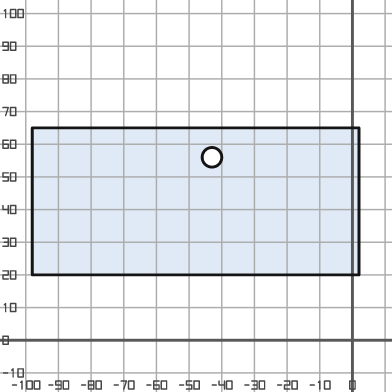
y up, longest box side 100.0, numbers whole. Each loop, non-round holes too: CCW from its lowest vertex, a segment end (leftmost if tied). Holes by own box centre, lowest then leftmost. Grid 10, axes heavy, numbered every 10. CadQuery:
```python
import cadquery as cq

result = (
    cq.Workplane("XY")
    .moveTo(-98.0, 20.0)
    .lineTo(2.0, 20.0)
    .lineTo(2.0, 65.0)
    .lineTo(-98.0, 65.0)
    .close()
    .moveTo(-43.0, 56.0)
    .circle(3.0)
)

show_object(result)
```